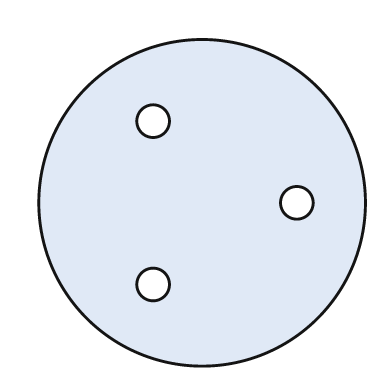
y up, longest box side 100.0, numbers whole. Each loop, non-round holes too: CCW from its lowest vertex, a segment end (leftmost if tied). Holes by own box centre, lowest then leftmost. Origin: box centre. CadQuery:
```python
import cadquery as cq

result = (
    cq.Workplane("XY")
    .moveTo(0.0, 0.0)
    .circle(50.0)
    .moveTo(-15.0, -25.0)
    .circle(5.0)
    .moveTo(29.0, 0.0)
    .circle(5.0)
    .moveTo(-15.0, 25.0)
    .circle(5.0)
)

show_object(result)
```